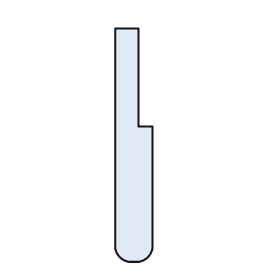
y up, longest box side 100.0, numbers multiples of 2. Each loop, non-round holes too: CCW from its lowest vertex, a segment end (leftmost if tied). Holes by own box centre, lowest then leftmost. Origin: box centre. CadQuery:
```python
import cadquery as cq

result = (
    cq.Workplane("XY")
    .moveTo(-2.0, -50.0)
    .lineTo(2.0, -50.0)
    .threePointArc((6.0, -48.0), (8.0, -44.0))
    .lineTo(8.0, 8.0)
    .lineTo(2.0, 8.0)
    .lineTo(2.0, 50.0)
    .lineTo(-8.0, 50.0)
    .lineTo(-8.0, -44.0)
    .threePointArc((-6.0, -48.0), (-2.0, -50.0))
    .close()
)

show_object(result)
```